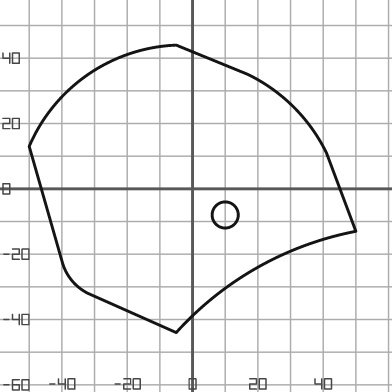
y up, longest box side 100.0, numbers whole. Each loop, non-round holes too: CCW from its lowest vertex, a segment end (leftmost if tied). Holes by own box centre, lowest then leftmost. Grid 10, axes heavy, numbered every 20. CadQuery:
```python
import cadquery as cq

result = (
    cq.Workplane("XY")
    .moveTo(-5.0, -44.0)
    .threePointArc((20.0, -24.0), (50.0, -13.0))
    .lineTo(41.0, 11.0)
    .threePointArc((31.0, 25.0), (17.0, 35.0))
    .lineTo(-5.0, 44.0)
    .threePointArc((-32.0, 35.0), (-50.0, 13.0))
    .lineTo(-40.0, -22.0)
    .threePointArc((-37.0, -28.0), (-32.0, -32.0))
    .close()
    .moveTo(10.0, -8.0)
    .circle(4.0)
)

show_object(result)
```